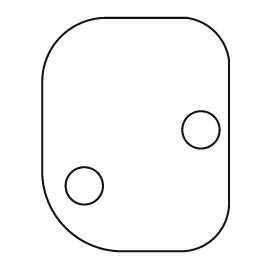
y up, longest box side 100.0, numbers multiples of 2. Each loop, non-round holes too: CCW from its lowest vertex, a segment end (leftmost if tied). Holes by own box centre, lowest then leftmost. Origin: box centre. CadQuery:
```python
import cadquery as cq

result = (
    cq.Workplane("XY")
    .moveTo(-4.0, -50.0)
    .lineTo(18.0, -50.0)
    .threePointArc((34.0, -44.0), (40.0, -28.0))
    .lineTo(40.0, 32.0)
    .threePointArc((34.0, 44.0), (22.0, 50.0))
    .lineTo(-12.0, 50.0)
    .threePointArc((-32.0, 42.0), (-40.0, 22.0))
    .lineTo(-40.0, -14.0)
    .threePointArc((-30.0, -40.0), (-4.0, -50.0))
    .close()
    .moveTo(-22.0, -22.0)
    .circle(8.0)
    .moveTo(28.0, 2.0)
    .circle(8.0)
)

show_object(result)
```